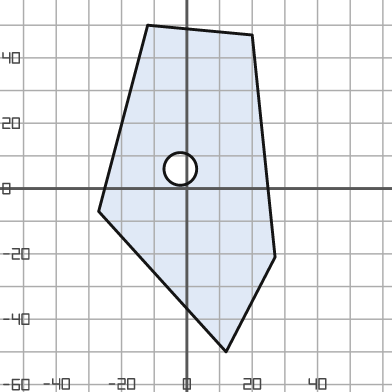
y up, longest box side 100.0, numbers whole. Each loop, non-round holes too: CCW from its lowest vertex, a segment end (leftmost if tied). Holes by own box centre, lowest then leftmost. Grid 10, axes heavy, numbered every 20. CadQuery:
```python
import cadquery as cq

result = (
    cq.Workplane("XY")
    .moveTo(12.0, -50.0)
    .lineTo(27.0, -21.0)
    .lineTo(20.0, 47.0)
    .lineTo(-12.0, 50.0)
    .lineTo(-27.0, -7.0)
    .close()
    .moveTo(-2.0, 6.0)
    .circle(5.0)
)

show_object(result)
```